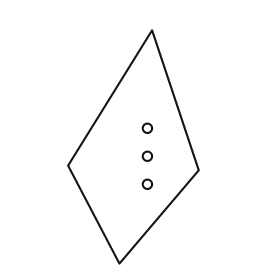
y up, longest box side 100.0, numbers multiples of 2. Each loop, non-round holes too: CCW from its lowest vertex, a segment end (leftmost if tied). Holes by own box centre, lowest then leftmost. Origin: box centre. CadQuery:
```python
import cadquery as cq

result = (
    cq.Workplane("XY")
    .moveTo(-6.0, -50.0)
    .lineTo(28.0, -10.0)
    .lineTo(8.0, 50.0)
    .lineTo(-28.0, -8.0)
    .close()
    .moveTo(6.0, -16.0)
    .circle(2.0)
    .moveTo(6.0, -4.0)
    .circle(2.0)
    .moveTo(6.0, 8.0)
    .circle(2.0)
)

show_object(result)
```